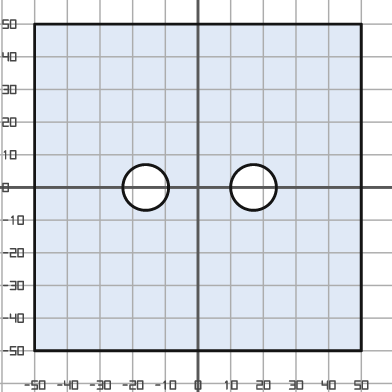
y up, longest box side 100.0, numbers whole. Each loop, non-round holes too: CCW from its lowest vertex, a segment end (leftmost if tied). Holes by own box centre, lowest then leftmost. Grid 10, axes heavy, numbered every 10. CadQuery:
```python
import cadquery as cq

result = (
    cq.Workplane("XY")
    .moveTo(-50.0, -50.0)
    .lineTo(50.0, -50.0)
    .lineTo(50.0, 50.0)
    .lineTo(-50.0, 50.0)
    .close()
    .moveTo(-16.0, 0.0)
    .circle(7.0)
    .moveTo(17.0, 0.0)
    .circle(7.0)
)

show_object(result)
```